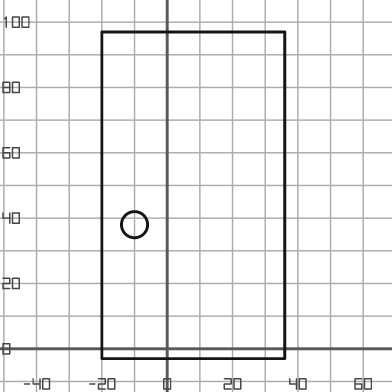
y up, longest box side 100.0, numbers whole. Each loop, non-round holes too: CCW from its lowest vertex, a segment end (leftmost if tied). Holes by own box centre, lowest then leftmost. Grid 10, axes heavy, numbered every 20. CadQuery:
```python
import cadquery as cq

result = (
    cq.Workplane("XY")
    .moveTo(-20.0, -3.0)
    .lineTo(36.0, -3.0)
    .lineTo(36.0, 97.0)
    .lineTo(-20.0, 97.0)
    .close()
    .moveTo(-10.0, 38.0)
    .circle(4.0)
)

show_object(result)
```